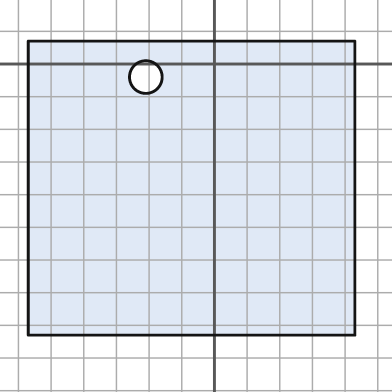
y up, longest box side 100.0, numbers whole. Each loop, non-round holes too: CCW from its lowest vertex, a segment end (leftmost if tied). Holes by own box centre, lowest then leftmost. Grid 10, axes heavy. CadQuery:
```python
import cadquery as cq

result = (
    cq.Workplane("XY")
    .moveTo(-57.0, -83.0)
    .lineTo(43.0, -83.0)
    .lineTo(43.0, 7.0)
    .lineTo(-57.0, 7.0)
    .close()
    .moveTo(-21.0, -4.0)
    .circle(5.0)
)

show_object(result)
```